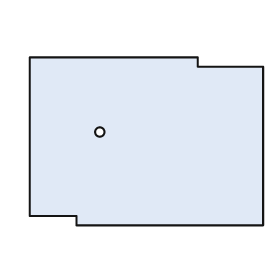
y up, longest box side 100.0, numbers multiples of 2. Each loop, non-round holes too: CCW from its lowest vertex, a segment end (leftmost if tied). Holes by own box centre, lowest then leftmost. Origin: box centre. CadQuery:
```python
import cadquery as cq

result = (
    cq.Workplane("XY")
    .moveTo(-30.0, -36.0)
    .lineTo(50.0, -36.0)
    .lineTo(50.0, 32.0)
    .lineTo(22.0, 32.0)
    .lineTo(22.0, 36.0)
    .lineTo(-50.0, 36.0)
    .lineTo(-50.0, -32.0)
    .lineTo(-30.0, -32.0)
    .close()
    .moveTo(-20.0, 4.0)
    .circle(2.0)
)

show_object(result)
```